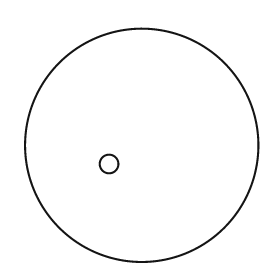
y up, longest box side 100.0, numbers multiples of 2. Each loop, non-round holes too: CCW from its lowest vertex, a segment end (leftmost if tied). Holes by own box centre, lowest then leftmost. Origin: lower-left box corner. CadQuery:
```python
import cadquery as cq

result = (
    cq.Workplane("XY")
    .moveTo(50.0, 50.0)
    .circle(50.0)
    .moveTo(36.0, 42.0)
    .circle(4.0)
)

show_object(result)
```